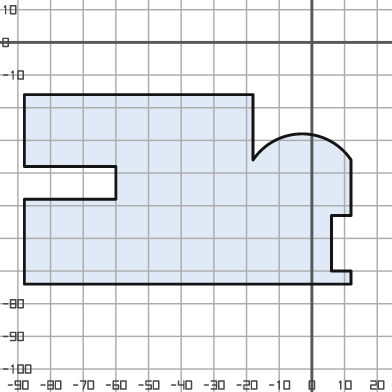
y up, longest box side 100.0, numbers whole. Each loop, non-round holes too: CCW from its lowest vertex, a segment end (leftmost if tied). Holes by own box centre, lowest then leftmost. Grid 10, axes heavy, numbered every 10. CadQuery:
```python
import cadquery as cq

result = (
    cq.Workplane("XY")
    .moveTo(-88.0, -74.0)
    .lineTo(12.0, -74.0)
    .lineTo(12.0, -70.0)
    .lineTo(6.0, -70.0)
    .lineTo(6.0, -53.0)
    .lineTo(12.0, -53.0)
    .lineTo(12.0, -36.0)
    .threePointArc((-3.0, -28.0), (-18.0, -36.0))
    .lineTo(-18.0, -16.0)
    .lineTo(-88.0, -16.0)
    .lineTo(-88.0, -38.0)
    .lineTo(-60.0, -38.0)
    .lineTo(-60.0, -48.0)
    .lineTo(-88.0, -48.0)
    .close()
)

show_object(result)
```